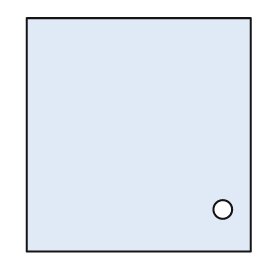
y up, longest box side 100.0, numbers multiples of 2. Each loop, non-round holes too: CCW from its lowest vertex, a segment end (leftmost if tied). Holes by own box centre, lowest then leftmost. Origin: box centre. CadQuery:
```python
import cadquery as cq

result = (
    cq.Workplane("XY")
    .moveTo(-48.0, -50.0)
    .lineTo(48.0, -50.0)
    .lineTo(48.0, 50.0)
    .lineTo(-48.0, 50.0)
    .close()
    .moveTo(36.0, -32.0)
    .circle(4.0)
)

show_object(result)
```